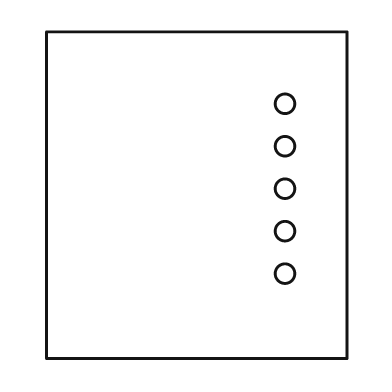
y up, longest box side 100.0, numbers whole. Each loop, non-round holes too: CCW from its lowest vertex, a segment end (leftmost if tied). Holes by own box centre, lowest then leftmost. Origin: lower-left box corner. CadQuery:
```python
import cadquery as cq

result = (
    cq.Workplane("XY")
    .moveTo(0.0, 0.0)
    .lineTo(92.0, 0.0)
    .lineTo(92.0, 100.0)
    .lineTo(0.0, 100.0)
    .close()
    .moveTo(73.0, 26.0)
    .circle(3.0)
    .moveTo(73.0, 39.0)
    .circle(3.0)
    .moveTo(73.0, 52.0)
    .circle(3.0)
    .moveTo(73.0, 65.0)
    .circle(3.0)
    .moveTo(73.0, 78.0)
    .circle(3.0)
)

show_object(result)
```